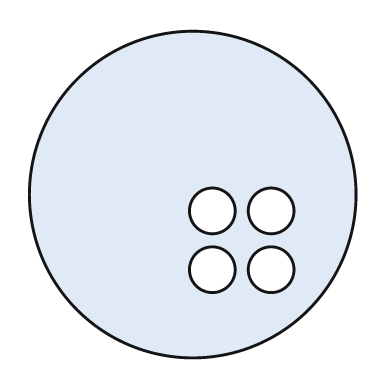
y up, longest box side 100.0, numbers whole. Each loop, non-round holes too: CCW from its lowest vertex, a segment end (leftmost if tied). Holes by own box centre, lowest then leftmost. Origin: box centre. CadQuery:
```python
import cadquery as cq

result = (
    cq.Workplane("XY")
    .moveTo(0.0, 0.0)
    .circle(50.0)
    .moveTo(6.0, -23.0)
    .circle(7.0)
    .moveTo(24.0, -23.0)
    .circle(7.0)
    .moveTo(6.0, -5.0)
    .circle(7.0)
    .moveTo(24.0, -5.0)
    .circle(7.0)
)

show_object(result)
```